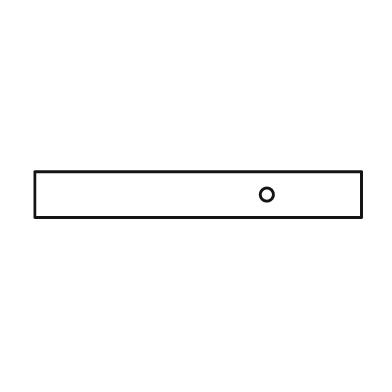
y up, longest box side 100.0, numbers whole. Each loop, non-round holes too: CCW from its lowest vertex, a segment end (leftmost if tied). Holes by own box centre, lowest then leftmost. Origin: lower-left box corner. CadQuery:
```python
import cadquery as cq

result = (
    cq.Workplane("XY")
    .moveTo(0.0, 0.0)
    .lineTo(100.0, 0.0)
    .lineTo(100.0, 14.0)
    .lineTo(0.0, 14.0)
    .close()
    .moveTo(71.0, 7.0)
    .circle(2.0)
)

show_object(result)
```